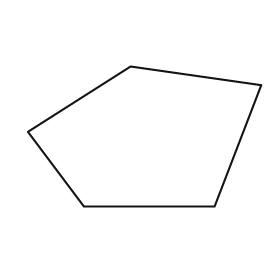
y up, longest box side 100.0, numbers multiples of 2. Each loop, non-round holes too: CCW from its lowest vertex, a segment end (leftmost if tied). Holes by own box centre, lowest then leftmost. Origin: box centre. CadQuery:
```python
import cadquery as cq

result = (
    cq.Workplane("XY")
    .moveTo(-26.0, -30.0)
    .lineTo(30.0, -30.0)
    .lineTo(50.0, 22.0)
    .lineTo(-6.0, 30.0)
    .lineTo(-50.0, 2.0)
    .close()
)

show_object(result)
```